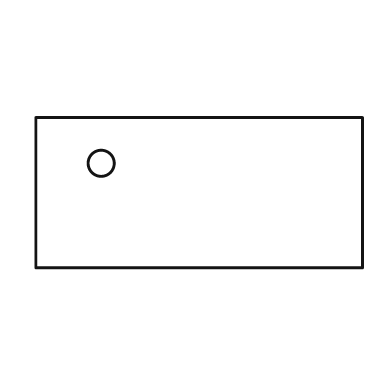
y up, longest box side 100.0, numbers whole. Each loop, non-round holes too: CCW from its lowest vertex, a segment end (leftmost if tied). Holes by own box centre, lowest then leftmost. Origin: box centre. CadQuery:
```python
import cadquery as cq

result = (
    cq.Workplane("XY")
    .moveTo(-50.0, -23.0)
    .lineTo(50.0, -23.0)
    .lineTo(50.0, 23.0)
    .lineTo(-50.0, 23.0)
    .close()
    .moveTo(-30.0, 9.0)
    .circle(4.0)
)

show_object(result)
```